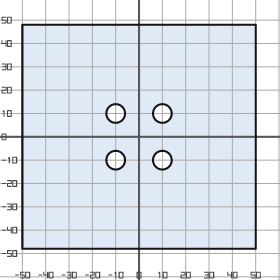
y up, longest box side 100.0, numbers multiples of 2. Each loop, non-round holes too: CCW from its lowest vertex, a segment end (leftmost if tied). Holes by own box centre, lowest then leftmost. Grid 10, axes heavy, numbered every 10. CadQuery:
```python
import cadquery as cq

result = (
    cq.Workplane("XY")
    .moveTo(-50.0, -48.0)
    .lineTo(50.0, -48.0)
    .lineTo(50.0, 48.0)
    .lineTo(-50.0, 48.0)
    .close()
    .moveTo(-10.0, -10.0)
    .circle(4.0)
    .moveTo(10.0, -10.0)
    .circle(4.0)
    .moveTo(-10.0, 10.0)
    .circle(4.0)
    .moveTo(10.0, 10.0)
    .circle(4.0)
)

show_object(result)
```